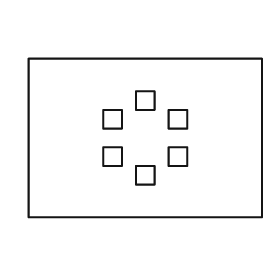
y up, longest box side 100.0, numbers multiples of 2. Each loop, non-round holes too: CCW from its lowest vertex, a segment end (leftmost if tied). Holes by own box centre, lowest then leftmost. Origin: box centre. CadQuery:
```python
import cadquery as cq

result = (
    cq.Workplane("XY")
    .moveTo(-50.0, -34.0)
    .lineTo(50.0, -34.0)
    .lineTo(50.0, 34.0)
    .lineTo(-50.0, 34.0)
    .close()
    .moveTo(-4.0, -20.0)
    .lineTo(4.0, -20.0)
    .lineTo(4.0, -12.0)
    .lineTo(-4.0, -12.0)
    .close()
    .moveTo(-18.0, -12.0)
    .lineTo(-10.0, -12.0)
    .lineTo(-10.0, -4.0)
    .lineTo(-18.0, -4.0)
    .close()
    .moveTo(10.0, -12.0)
    .lineTo(18.0, -12.0)
    .lineTo(18.0, -4.0)
    .lineTo(10.0, -4.0)
    .close()
    .moveTo(-18.0, 4.0)
    .lineTo(-10.0, 4.0)
    .lineTo(-10.0, 12.0)
    .lineTo(-18.0, 12.0)
    .close()
    .moveTo(10.0, 4.0)
    .lineTo(18.0, 4.0)
    .lineTo(18.0, 12.0)
    .lineTo(10.0, 12.0)
    .close()
    .moveTo(-4.0, 12.0)
    .lineTo(4.0, 12.0)
    .lineTo(4.0, 20.0)
    .lineTo(-4.0, 20.0)
    .close()
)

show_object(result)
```